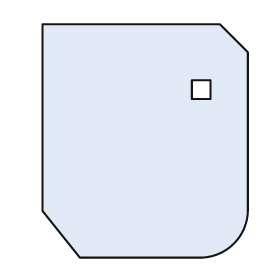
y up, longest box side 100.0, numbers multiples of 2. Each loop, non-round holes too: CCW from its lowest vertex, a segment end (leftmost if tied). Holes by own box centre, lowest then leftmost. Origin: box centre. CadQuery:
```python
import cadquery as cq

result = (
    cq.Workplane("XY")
    .moveTo(-28.0, -50.0)
    .lineTo(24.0, -50.0)
    .threePointArc((38.0, -44.0), (44.0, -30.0))
    .lineTo(44.0, 38.0)
    .lineTo(32.0, 50.0)
    .lineTo(-44.0, 50.0)
    .lineTo(-44.0, -30.0)
    .close()
    .moveTo(20.0, 18.0)
    .lineTo(28.0, 18.0)
    .lineTo(28.0, 26.0)
    .lineTo(20.0, 26.0)
    .close()
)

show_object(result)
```